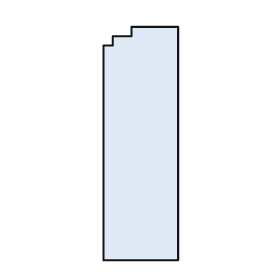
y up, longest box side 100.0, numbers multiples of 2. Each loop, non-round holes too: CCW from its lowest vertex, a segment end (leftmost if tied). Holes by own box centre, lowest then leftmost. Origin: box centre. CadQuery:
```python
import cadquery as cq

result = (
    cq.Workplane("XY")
    .moveTo(-16.0, -50.0)
    .lineTo(16.0, -50.0)
    .lineTo(16.0, 50.0)
    .lineTo(-4.0, 50.0)
    .lineTo(-4.0, 46.0)
    .lineTo(-12.0, 46.0)
    .lineTo(-12.0, 42.0)
    .lineTo(-16.0, 42.0)
    .close()
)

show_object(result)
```